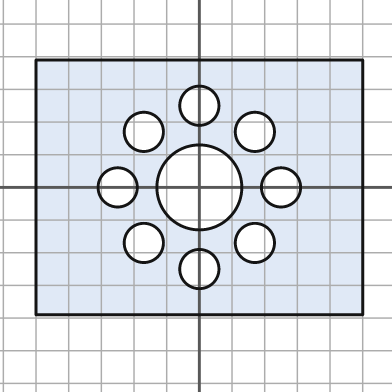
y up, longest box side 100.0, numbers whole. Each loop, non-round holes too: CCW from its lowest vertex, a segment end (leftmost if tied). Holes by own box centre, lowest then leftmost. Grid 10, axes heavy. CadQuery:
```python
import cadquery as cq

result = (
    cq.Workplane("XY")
    .moveTo(-50.0, -39.0)
    .lineTo(50.0, -39.0)
    .lineTo(50.0, 39.0)
    .lineTo(-50.0, 39.0)
    .close()
    .moveTo(0.0, -25.0)
    .circle(6.0)
    .moveTo(-17.0, -17.0)
    .circle(6.0)
    .moveTo(17.0, -17.0)
    .circle(6.0)
    .moveTo(-25.0, 0.0)
    .circle(6.0)
    .moveTo(0.0, 0.0)
    .circle(13.0)
    .moveTo(25.0, 0.0)
    .circle(6.0)
    .moveTo(-17.0, 17.0)
    .circle(6.0)
    .moveTo(17.0, 17.0)
    .circle(6.0)
    .moveTo(0.0, 25.0)
    .circle(6.0)
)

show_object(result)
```